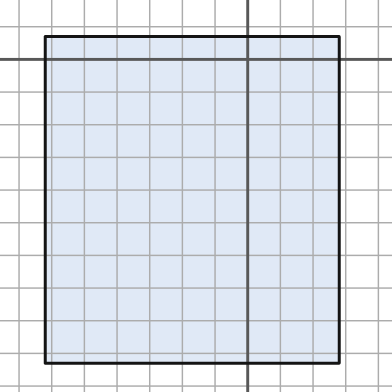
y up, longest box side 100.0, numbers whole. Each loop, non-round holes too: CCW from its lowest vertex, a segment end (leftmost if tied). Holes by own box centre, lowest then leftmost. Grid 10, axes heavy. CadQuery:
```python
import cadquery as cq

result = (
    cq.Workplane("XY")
    .moveTo(-62.0, -93.0)
    .lineTo(28.0, -93.0)
    .lineTo(28.0, 7.0)
    .lineTo(-62.0, 7.0)
    .close()
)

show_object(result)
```